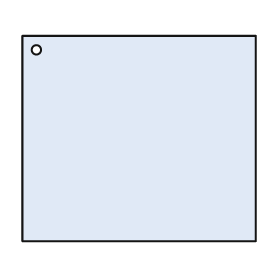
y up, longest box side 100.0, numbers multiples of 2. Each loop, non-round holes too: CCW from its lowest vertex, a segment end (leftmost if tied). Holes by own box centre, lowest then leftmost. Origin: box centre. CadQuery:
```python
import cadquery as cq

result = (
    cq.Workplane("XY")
    .moveTo(-50.0, -44.0)
    .lineTo(50.0, -44.0)
    .lineTo(50.0, 44.0)
    .lineTo(-50.0, 44.0)
    .close()
    .moveTo(-44.0, 38.0)
    .circle(2.0)
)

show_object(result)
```